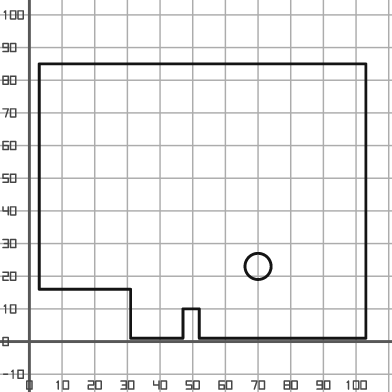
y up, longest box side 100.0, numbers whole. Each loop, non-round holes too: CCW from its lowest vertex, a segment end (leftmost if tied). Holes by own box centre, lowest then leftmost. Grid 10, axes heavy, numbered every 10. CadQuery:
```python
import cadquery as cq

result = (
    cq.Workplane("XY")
    .moveTo(31.0, 1.0)
    .lineTo(47.0, 1.0)
    .lineTo(47.0, 10.0)
    .lineTo(52.0, 10.0)
    .lineTo(52.0, 1.0)
    .lineTo(103.0, 1.0)
    .lineTo(103.0, 85.0)
    .lineTo(3.0, 85.0)
    .lineTo(3.0, 16.0)
    .lineTo(31.0, 16.0)
    .close()
    .moveTo(70.0, 23.0)
    .circle(4.0)
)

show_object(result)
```